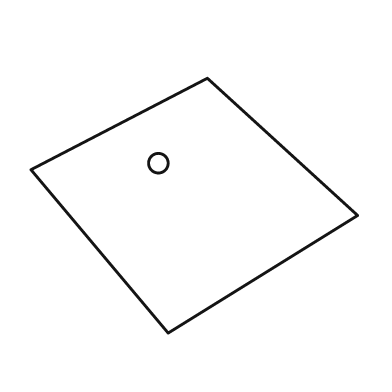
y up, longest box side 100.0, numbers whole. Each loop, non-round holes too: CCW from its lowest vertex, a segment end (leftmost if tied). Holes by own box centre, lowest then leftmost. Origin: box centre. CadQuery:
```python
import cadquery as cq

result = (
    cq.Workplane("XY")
    .moveTo(-8.0, -39.0)
    .lineTo(50.0, -3.0)
    .lineTo(4.0, 39.0)
    .lineTo(-50.0, 11.0)
    .close()
    .moveTo(-11.0, 13.0)
    .circle(3.0)
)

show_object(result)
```